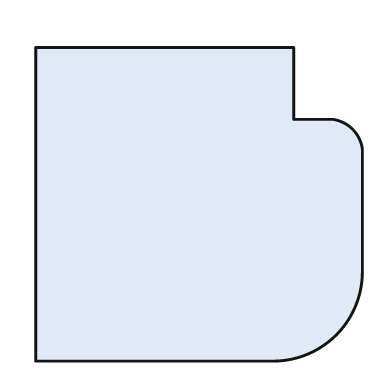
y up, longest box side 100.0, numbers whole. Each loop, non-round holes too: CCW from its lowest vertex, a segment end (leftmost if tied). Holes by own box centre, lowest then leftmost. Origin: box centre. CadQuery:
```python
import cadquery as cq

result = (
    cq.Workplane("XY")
    .moveTo(-50.0, -48.0)
    .lineTo(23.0, -48.0)
    .threePointArc((42.0, -40.0), (50.0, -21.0))
    .lineTo(50.0, 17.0)
    .threePointArc((47.0, 23.0), (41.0, 26.0))
    .lineTo(29.0, 26.0)
    .lineTo(29.0, 48.0)
    .lineTo(-50.0, 48.0)
    .close()
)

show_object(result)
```